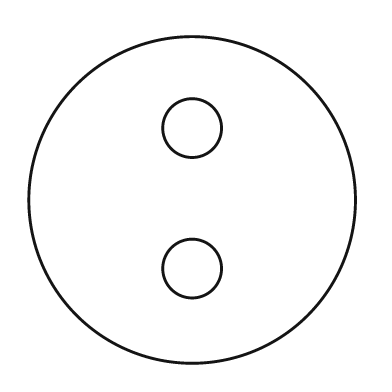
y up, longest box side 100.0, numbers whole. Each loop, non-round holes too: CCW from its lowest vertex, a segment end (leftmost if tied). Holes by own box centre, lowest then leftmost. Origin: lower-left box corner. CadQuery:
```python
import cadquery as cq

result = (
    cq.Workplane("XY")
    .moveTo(50.0, 50.0)
    .circle(50.0)
    .moveTo(50.0, 29.0)
    .circle(9.0)
    .moveTo(50.0, 72.0)
    .circle(9.0)
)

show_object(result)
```